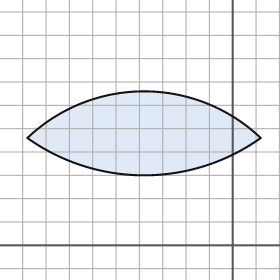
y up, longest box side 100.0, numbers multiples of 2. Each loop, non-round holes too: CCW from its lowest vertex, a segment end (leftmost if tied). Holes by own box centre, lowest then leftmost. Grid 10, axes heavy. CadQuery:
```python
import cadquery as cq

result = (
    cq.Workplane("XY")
    .moveTo(-88.0, 46.0)
    .threePointArc((-38.0, 30.0), (12.0, 46.0))
    .threePointArc((-38.0, 66.0), (-88.0, 46.0))
    .close()
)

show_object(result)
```